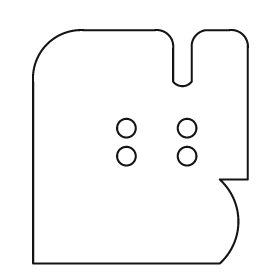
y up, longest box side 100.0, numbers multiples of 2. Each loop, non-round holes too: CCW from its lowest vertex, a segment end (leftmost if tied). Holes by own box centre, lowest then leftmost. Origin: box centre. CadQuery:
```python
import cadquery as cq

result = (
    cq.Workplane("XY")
    .moveTo(-46.0, -50.0)
    .lineTo(34.0, -50.0)
    .threePointArc((42.0, -32.0), (34.0, -14.0))
    .lineTo(46.0, -14.0)
    .lineTo(46.0, 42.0)
    .threePointArc((44.0, 48.0), (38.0, 50.0))
    .lineTo(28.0, 50.0)
    .threePointArc((24.0, 48.0), (22.0, 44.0))
    .lineTo(22.0, 28.0)
    .threePointArc((18.0, 26.0), (14.0, 28.0))
    .lineTo(14.0, 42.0)
    .threePointArc((12.0, 48.0), (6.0, 50.0))
    .lineTo(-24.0, 50.0)
    .threePointArc((-40.0, 44.0), (-46.0, 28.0))
    .close()
    .moveTo(-6.0, -4.0)
    .circle(4.0)
    .moveTo(20.0, -4.0)
    .circle(4.0)
    .moveTo(-6.0, 8.0)
    .circle(4.0)
    .moveTo(20.0, 8.0)
    .circle(4.0)
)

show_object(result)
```